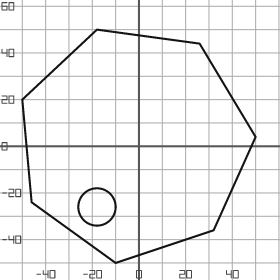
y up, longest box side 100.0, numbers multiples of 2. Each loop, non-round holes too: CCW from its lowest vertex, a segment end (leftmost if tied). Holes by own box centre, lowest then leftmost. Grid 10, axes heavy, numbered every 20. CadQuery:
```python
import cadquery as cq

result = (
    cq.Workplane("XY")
    .moveTo(-10.0, -50.0)
    .lineTo(32.0, -36.0)
    .lineTo(50.0, 4.0)
    .lineTo(26.0, 44.0)
    .lineTo(-18.0, 50.0)
    .lineTo(-50.0, 20.0)
    .lineTo(-46.0, -24.0)
    .close()
    .moveTo(-18.0, -26.0)
    .circle(8.0)
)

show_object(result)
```